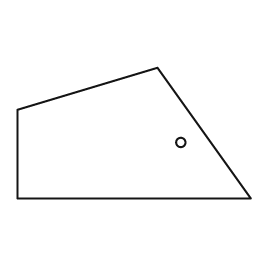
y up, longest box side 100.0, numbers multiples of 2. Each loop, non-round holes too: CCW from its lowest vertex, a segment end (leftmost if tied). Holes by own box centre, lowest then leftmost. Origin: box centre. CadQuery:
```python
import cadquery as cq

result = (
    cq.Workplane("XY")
    .moveTo(-50.0, -28.0)
    .lineTo(50.0, -28.0)
    .lineTo(10.0, 28.0)
    .lineTo(-50.0, 10.0)
    .close()
    .moveTo(20.0, -4.0)
    .circle(2.0)
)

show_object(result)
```